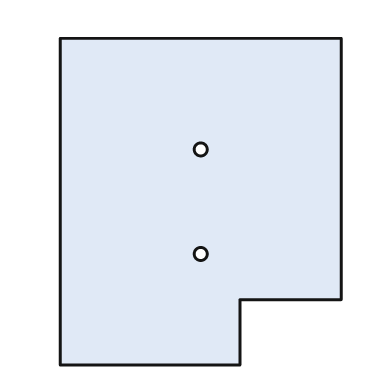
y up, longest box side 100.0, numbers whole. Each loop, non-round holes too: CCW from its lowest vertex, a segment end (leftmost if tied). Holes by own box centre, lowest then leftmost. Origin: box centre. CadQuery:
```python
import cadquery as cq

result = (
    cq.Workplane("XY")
    .moveTo(-43.0, -50.0)
    .lineTo(12.0, -50.0)
    .lineTo(12.0, -30.0)
    .lineTo(43.0, -30.0)
    .lineTo(43.0, 50.0)
    .lineTo(-43.0, 50.0)
    .close()
    .moveTo(0.0, -16.0)
    .circle(2.0)
    .moveTo(0.0, 16.0)
    .circle(2.0)
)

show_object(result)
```